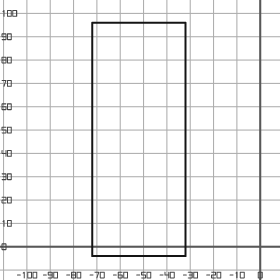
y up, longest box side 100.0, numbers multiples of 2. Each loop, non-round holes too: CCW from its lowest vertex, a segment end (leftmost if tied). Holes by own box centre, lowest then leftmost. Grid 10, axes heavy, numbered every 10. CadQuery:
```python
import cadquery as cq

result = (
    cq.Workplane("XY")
    .moveTo(-72.0, -4.0)
    .lineTo(-32.0, -4.0)
    .lineTo(-32.0, 96.0)
    .lineTo(-72.0, 96.0)
    .close()
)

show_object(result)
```